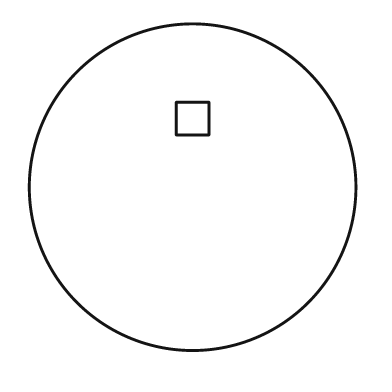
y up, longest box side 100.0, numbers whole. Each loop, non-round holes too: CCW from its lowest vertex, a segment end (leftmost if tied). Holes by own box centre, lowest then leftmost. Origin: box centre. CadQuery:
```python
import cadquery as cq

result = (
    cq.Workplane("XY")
    .moveTo(0.0, 0.0)
    .circle(50.0)
    .moveTo(-5.0, 16.0)
    .lineTo(5.0, 16.0)
    .lineTo(5.0, 26.0)
    .lineTo(-5.0, 26.0)
    .close()
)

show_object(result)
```